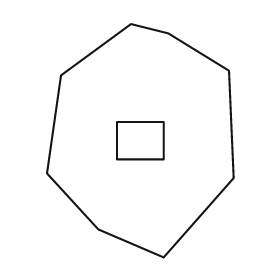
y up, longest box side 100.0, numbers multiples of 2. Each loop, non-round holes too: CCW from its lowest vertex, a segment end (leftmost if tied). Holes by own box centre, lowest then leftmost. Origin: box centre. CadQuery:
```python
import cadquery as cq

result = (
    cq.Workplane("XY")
    .moveTo(10.0, -50.0)
    .lineTo(40.0, -16.0)
    .lineTo(38.0, 30.0)
    .lineTo(12.0, 46.0)
    .lineTo(-4.0, 50.0)
    .lineTo(-34.0, 28.0)
    .lineTo(-40.0, -14.0)
    .lineTo(-18.0, -38.0)
    .close()
    .moveTo(-10.0, -8.0)
    .lineTo(10.0, -8.0)
    .lineTo(10.0, 8.0)
    .lineTo(-10.0, 8.0)
    .close()
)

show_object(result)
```